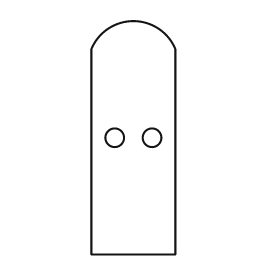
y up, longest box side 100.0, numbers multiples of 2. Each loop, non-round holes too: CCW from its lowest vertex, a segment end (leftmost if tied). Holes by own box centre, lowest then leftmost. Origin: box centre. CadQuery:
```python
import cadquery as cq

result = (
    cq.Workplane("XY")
    .moveTo(-18.0, -50.0)
    .lineTo(18.0, -50.0)
    .lineTo(18.0, 38.0)
    .threePointArc((0.0, 50.0), (-18.0, 38.0))
    .close()
    .moveTo(-8.0, 0.0)
    .circle(4.0)
    .moveTo(8.0, 0.0)
    .circle(4.0)
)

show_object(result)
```